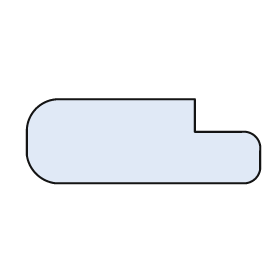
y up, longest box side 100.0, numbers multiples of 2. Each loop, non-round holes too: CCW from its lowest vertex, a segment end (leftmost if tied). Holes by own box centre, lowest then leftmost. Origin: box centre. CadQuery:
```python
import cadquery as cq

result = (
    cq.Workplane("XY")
    .moveTo(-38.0, -18.0)
    .lineTo(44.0, -18.0)
    .threePointArc((48.0, -16.0), (50.0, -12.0))
    .lineTo(50.0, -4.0)
    .threePointArc((48.0, 2.0), (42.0, 4.0))
    .lineTo(22.0, 4.0)
    .lineTo(22.0, 18.0)
    .lineTo(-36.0, 18.0)
    .threePointArc((-46.0, 14.0), (-50.0, 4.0))
    .lineTo(-50.0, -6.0)
    .threePointArc((-46.0, -14.0), (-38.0, -18.0))
    .close()
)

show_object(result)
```